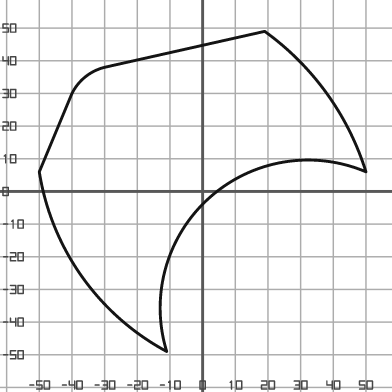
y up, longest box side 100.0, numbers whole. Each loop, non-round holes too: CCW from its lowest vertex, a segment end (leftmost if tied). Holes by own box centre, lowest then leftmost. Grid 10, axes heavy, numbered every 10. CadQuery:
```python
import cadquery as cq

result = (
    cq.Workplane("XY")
    .moveTo(-11.0, -49.0)
    .threePointArc((2.0, -2.0), (50.0, 6.0))
    .threePointArc((38.0, 30.0), (19.0, 49.0))
    .lineTo(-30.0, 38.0)
    .threePointArc((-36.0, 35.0), (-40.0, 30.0))
    .lineTo(-50.0, 6.0)
    .threePointArc((-37.0, -26.0), (-11.0, -49.0))
    .close()
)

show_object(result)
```